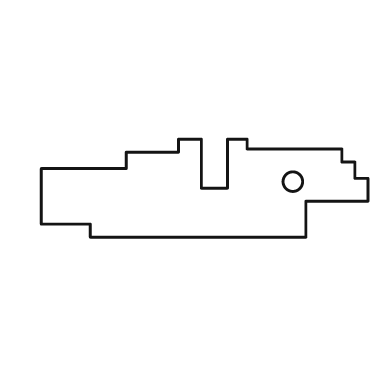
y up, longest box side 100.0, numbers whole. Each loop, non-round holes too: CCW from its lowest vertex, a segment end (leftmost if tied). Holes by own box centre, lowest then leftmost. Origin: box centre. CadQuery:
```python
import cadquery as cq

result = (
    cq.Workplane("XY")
    .moveTo(-35.0, -15.0)
    .lineTo(31.0, -15.0)
    .lineTo(31.0, -4.0)
    .lineTo(50.0, -4.0)
    .lineTo(50.0, 3.0)
    .lineTo(46.0, 3.0)
    .lineTo(46.0, 8.0)
    .lineTo(42.0, 8.0)
    .lineTo(42.0, 12.0)
    .lineTo(13.0, 12.0)
    .lineTo(13.0, 15.0)
    .lineTo(7.0, 15.0)
    .lineTo(7.0, 0.0)
    .lineTo(-1.0, 0.0)
    .lineTo(-1.0, 15.0)
    .lineTo(-8.0, 15.0)
    .lineTo(-8.0, 11.0)
    .lineTo(-24.0, 11.0)
    .lineTo(-24.0, 6.0)
    .lineTo(-50.0, 6.0)
    .lineTo(-50.0, -11.0)
    .lineTo(-35.0, -11.0)
    .close()
    .moveTo(27.0, 2.0)
    .circle(3.0)
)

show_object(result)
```